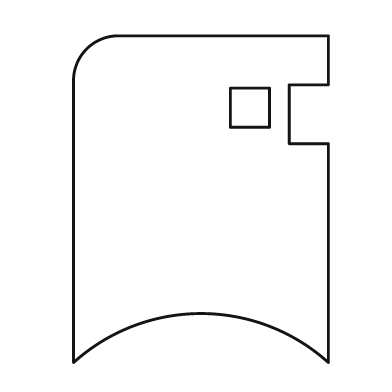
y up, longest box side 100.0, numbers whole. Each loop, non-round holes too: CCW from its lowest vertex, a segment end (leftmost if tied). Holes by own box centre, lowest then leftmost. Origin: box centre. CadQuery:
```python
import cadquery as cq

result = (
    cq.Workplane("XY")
    .moveTo(-39.0, -50.0)
    .threePointArc((0.0, -35.0), (39.0, -50.0))
    .lineTo(39.0, 17.0)
    .lineTo(27.0, 17.0)
    .lineTo(27.0, 35.0)
    .lineTo(39.0, 35.0)
    .lineTo(39.0, 50.0)
    .lineTo(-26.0, 50.0)
    .threePointArc((-35.0, 46.0), (-39.0, 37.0))
    .close()
    .moveTo(9.0, 22.0)
    .lineTo(21.0, 22.0)
    .lineTo(21.0, 34.0)
    .lineTo(9.0, 34.0)
    .close()
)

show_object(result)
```